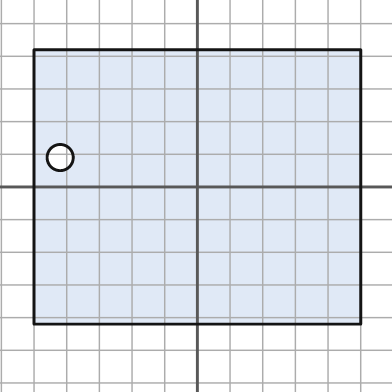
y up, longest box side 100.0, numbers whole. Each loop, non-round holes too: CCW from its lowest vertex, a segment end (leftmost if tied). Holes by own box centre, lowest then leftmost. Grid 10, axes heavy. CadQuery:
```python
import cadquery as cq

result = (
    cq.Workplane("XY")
    .moveTo(-50.0, -42.0)
    .lineTo(50.0, -42.0)
    .lineTo(50.0, 42.0)
    .lineTo(-50.0, 42.0)
    .close()
    .moveTo(-42.0, 9.0)
    .circle(4.0)
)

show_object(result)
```